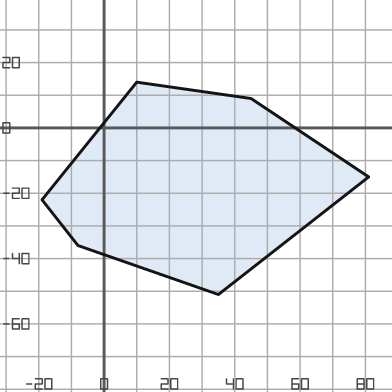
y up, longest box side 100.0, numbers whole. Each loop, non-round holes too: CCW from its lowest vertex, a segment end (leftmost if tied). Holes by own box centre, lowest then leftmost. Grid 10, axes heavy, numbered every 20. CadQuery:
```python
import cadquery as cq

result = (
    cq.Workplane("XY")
    .moveTo(35.0, -51.0)
    .lineTo(81.0, -15.0)
    .lineTo(45.0, 9.0)
    .lineTo(10.0, 14.0)
    .lineTo(-19.0, -22.0)
    .lineTo(-8.0, -36.0)
    .close()
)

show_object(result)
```